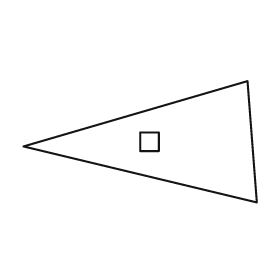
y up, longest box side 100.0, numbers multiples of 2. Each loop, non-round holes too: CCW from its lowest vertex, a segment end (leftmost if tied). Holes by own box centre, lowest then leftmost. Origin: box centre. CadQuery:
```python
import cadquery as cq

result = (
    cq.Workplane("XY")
    .moveTo(50.0, -26.0)
    .lineTo(46.0, 26.0)
    .lineTo(-50.0, -2.0)
    .close()
    .moveTo(0.0, -4.0)
    .lineTo(8.0, -4.0)
    .lineTo(8.0, 4.0)
    .lineTo(0.0, 4.0)
    .close()
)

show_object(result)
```